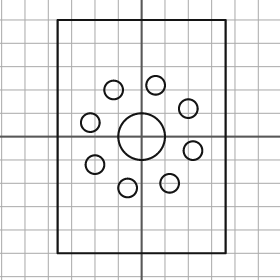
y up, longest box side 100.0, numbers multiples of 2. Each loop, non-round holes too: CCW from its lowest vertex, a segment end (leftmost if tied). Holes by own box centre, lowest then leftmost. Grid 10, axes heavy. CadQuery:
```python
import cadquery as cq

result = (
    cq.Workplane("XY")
    .moveTo(-36.0, -50.0)
    .lineTo(36.0, -50.0)
    .lineTo(36.0, 50.0)
    .lineTo(-36.0, 50.0)
    .close()
    .moveTo(-6.0, -22.0)
    .circle(4.0)
    .moveTo(12.0, -20.0)
    .circle(4.0)
    .moveTo(-20.0, -12.0)
    .circle(4.0)
    .moveTo(22.0, -6.0)
    .circle(4.0)
    .moveTo(0.0, 0.0)
    .circle(10.0)
    .moveTo(-22.0, 6.0)
    .circle(4.0)
    .moveTo(20.0, 12.0)
    .circle(4.0)
    .moveTo(-12.0, 20.0)
    .circle(4.0)
    .moveTo(6.0, 22.0)
    .circle(4.0)
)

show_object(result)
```